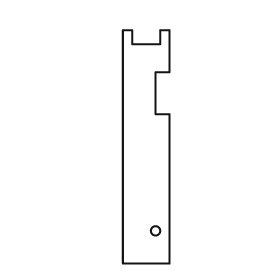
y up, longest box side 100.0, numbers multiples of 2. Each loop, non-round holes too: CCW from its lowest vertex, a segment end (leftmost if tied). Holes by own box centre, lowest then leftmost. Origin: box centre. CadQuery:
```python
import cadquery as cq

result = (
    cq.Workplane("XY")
    .moveTo(-10.0, -50.0)
    .lineTo(10.0, -50.0)
    .lineTo(10.0, 14.0)
    .lineTo(4.0, 14.0)
    .lineTo(4.0, 32.0)
    .lineTo(10.0, 32.0)
    .lineTo(10.0, 50.0)
    .lineTo(6.0, 50.0)
    .lineTo(6.0, 44.0)
    .lineTo(-6.0, 44.0)
    .lineTo(-6.0, 50.0)
    .lineTo(-10.0, 50.0)
    .close()
    .moveTo(4.0, -36.0)
    .circle(2.0)
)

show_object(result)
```